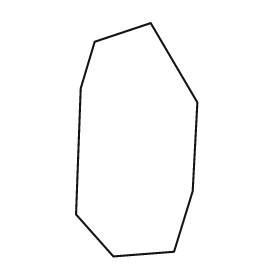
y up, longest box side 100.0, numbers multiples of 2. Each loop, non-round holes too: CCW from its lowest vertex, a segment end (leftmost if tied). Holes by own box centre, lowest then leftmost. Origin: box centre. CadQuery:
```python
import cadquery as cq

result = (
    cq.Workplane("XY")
    .moveTo(-10.0, -50.0)
    .lineTo(16.0, -48.0)
    .lineTo(24.0, -22.0)
    .lineTo(26.0, 16.0)
    .lineTo(6.0, 50.0)
    .lineTo(-18.0, 42.0)
    .lineTo(-24.0, 22.0)
    .lineTo(-26.0, -32.0)
    .close()
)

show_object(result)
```